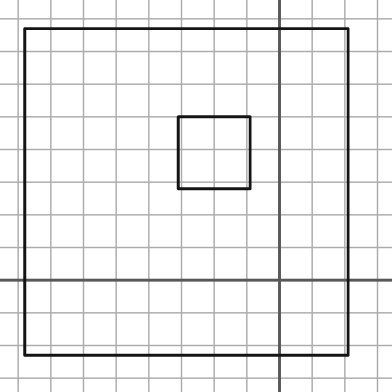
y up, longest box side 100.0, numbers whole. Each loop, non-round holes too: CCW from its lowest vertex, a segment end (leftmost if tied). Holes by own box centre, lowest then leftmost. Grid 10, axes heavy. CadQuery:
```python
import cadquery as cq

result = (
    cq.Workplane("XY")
    .moveTo(-78.0, -23.0)
    .lineTo(21.0, -23.0)
    .lineTo(21.0, 77.0)
    .lineTo(-78.0, 77.0)
    .close()
    .moveTo(-31.0, 28.0)
    .lineTo(-9.0, 28.0)
    .lineTo(-9.0, 50.0)
    .lineTo(-31.0, 50.0)
    .close()
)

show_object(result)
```